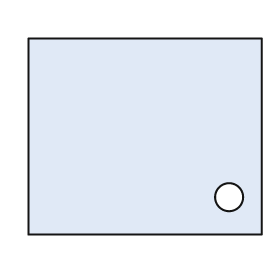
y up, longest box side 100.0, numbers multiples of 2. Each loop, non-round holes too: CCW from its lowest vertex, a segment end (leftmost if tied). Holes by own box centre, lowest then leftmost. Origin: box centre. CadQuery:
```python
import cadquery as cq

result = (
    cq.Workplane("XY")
    .moveTo(-50.0, -42.0)
    .lineTo(50.0, -42.0)
    .lineTo(50.0, 42.0)
    .lineTo(-50.0, 42.0)
    .close()
    .moveTo(36.0, -26.0)
    .circle(6.0)
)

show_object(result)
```